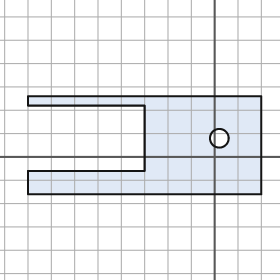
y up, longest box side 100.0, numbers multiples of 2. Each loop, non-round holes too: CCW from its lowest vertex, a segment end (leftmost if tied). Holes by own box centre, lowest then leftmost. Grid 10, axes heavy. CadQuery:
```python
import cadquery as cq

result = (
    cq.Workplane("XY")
    .moveTo(-80.0, -16.0)
    .lineTo(20.0, -16.0)
    .lineTo(20.0, 26.0)
    .lineTo(-80.0, 26.0)
    .lineTo(-80.0, 22.0)
    .lineTo(-30.0, 22.0)
    .lineTo(-30.0, -6.0)
    .lineTo(-80.0, -6.0)
    .close()
    .moveTo(2.0, 8.0)
    .circle(4.0)
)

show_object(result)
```